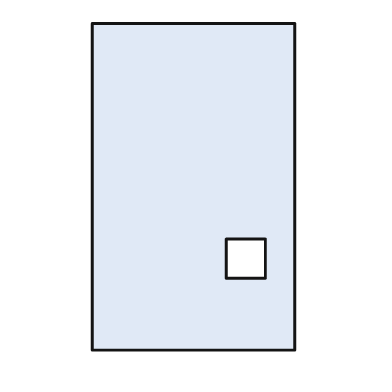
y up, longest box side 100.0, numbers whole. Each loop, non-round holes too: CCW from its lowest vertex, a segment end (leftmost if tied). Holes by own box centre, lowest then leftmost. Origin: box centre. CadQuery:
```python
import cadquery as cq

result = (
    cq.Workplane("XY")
    .moveTo(-31.0, -50.0)
    .lineTo(31.0, -50.0)
    .lineTo(31.0, 50.0)
    .lineTo(-31.0, 50.0)
    .close()
    .moveTo(10.0, -28.0)
    .lineTo(22.0, -28.0)
    .lineTo(22.0, -16.0)
    .lineTo(10.0, -16.0)
    .close()
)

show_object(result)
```